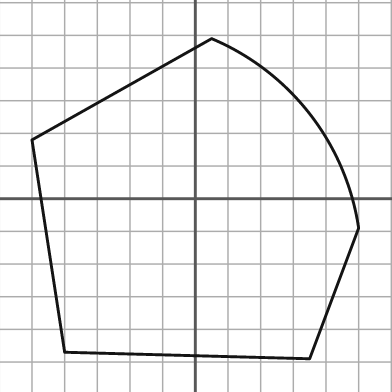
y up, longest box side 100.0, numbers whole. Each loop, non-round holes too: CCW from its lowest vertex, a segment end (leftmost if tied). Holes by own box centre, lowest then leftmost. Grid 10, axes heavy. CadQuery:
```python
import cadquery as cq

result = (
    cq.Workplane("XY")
    .moveTo(35.0, -49.0)
    .lineTo(50.0, -9.0)
    .threePointArc((35.0, 26.0), (5.0, 49.0))
    .lineTo(-50.0, 18.0)
    .lineTo(-40.0, -47.0)
    .close()
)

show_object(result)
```